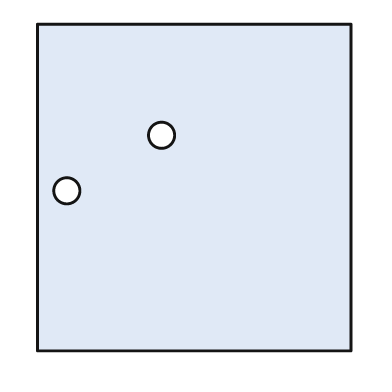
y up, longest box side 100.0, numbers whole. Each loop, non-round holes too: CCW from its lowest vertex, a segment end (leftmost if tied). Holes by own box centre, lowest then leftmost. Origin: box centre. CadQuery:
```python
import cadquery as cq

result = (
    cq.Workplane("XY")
    .moveTo(-48.0, -50.0)
    .lineTo(48.0, -50.0)
    .lineTo(48.0, 50.0)
    .lineTo(-48.0, 50.0)
    .close()
    .moveTo(-39.0, -1.0)
    .circle(4.0)
    .moveTo(-10.0, 16.0)
    .circle(4.0)
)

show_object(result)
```